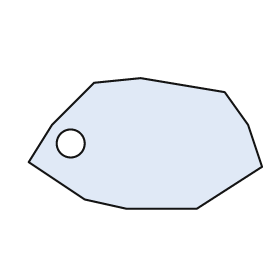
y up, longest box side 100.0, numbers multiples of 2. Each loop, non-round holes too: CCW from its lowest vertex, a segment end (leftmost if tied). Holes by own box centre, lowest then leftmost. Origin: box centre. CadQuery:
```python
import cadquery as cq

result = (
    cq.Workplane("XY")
    .moveTo(-8.0, -28.0)
    .lineTo(22.0, -28.0)
    .lineTo(50.0, -10.0)
    .lineTo(44.0, 8.0)
    .lineTo(34.0, 22.0)
    .lineTo(-2.0, 28.0)
    .lineTo(-22.0, 26.0)
    .lineTo(-40.0, 8.0)
    .lineTo(-50.0, -8.0)
    .lineTo(-26.0, -24.0)
    .close()
    .moveTo(-32.0, 0.0)
    .circle(6.0)
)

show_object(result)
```